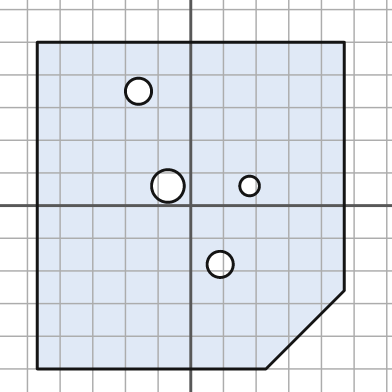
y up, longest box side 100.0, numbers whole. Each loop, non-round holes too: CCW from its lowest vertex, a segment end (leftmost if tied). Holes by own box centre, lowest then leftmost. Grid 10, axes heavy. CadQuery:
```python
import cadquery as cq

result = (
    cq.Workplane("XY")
    .moveTo(-47.0, -50.0)
    .lineTo(23.0, -50.0)
    .lineTo(47.0, -26.0)
    .lineTo(47.0, 50.0)
    .lineTo(-47.0, 50.0)
    .close()
    .moveTo(9.0, -18.0)
    .circle(4.0)
    .moveTo(-7.0, 6.0)
    .circle(5.0)
    .moveTo(18.0, 6.0)
    .circle(3.0)
    .moveTo(-16.0, 35.0)
    .circle(4.0)
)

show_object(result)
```